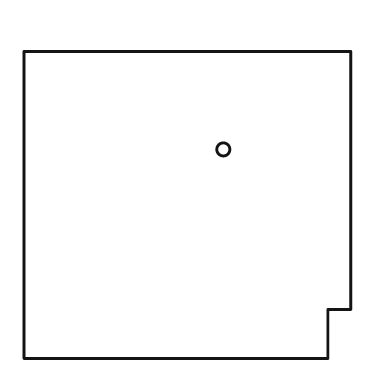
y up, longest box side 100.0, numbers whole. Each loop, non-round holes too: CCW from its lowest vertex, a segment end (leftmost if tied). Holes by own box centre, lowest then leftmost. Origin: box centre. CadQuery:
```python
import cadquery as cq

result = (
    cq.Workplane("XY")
    .moveTo(-50.0, -47.0)
    .lineTo(43.0, -47.0)
    .lineTo(43.0, -32.0)
    .lineTo(50.0, -32.0)
    .lineTo(50.0, 47.0)
    .lineTo(-50.0, 47.0)
    .close()
    .moveTo(11.0, 17.0)
    .circle(2.0)
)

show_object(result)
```